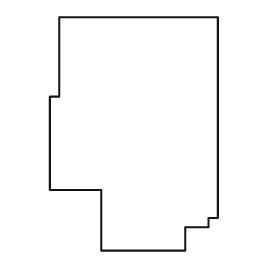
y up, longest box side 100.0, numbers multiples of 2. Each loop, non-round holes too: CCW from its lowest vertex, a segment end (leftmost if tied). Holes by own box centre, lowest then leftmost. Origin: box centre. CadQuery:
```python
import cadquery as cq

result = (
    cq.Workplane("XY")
    .moveTo(-14.0, -50.0)
    .lineTo(22.0, -50.0)
    .lineTo(22.0, -40.0)
    .lineTo(32.0, -40.0)
    .lineTo(32.0, -36.0)
    .lineTo(36.0, -36.0)
    .lineTo(36.0, 50.0)
    .lineTo(-32.0, 50.0)
    .lineTo(-32.0, 16.0)
    .lineTo(-36.0, 16.0)
    .lineTo(-36.0, -24.0)
    .lineTo(-14.0, -24.0)
    .close()
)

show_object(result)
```